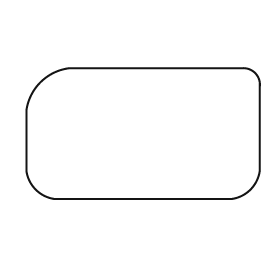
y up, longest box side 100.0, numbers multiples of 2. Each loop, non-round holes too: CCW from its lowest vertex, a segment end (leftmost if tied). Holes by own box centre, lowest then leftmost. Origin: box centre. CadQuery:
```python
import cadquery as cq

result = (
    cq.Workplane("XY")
    .moveTo(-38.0, -28.0)
    .lineTo(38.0, -28.0)
    .threePointArc((46.0, -24.0), (50.0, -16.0))
    .lineTo(50.0, 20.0)
    .threePointArc((48.0, 26.0), (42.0, 28.0))
    .lineTo(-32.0, 28.0)
    .threePointArc((-44.0, 22.0), (-50.0, 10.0))
    .lineTo(-50.0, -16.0)
    .threePointArc((-46.0, -24.0), (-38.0, -28.0))
    .close()
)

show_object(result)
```